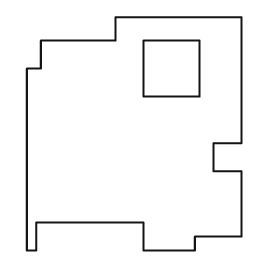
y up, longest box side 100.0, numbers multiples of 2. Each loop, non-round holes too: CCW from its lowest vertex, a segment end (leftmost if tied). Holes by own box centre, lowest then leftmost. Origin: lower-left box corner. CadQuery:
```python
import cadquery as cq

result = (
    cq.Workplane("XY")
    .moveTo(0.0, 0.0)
    .lineTo(4.0, 0.0)
    .lineTo(4.0, 12.0)
    .lineTo(50.0, 12.0)
    .lineTo(50.0, 0.0)
    .lineTo(72.0, 0.0)
    .lineTo(72.0, 6.0)
    .lineTo(92.0, 6.0)
    .lineTo(92.0, 34.0)
    .lineTo(80.0, 34.0)
    .lineTo(80.0, 46.0)
    .lineTo(92.0, 46.0)
    .lineTo(92.0, 100.0)
    .lineTo(38.0, 100.0)
    .lineTo(38.0, 90.0)
    .lineTo(6.0, 90.0)
    .lineTo(6.0, 78.0)
    .lineTo(0.0, 78.0)
    .close()
    .moveTo(50.0, 66.0)
    .lineTo(74.0, 66.0)
    .lineTo(74.0, 90.0)
    .lineTo(50.0, 90.0)
    .close()
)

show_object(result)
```